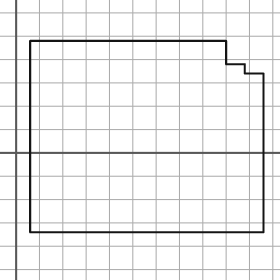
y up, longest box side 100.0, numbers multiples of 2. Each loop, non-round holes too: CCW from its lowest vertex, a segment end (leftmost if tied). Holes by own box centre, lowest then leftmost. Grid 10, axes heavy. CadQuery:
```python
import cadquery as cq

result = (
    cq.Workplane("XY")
    .moveTo(6.0, -34.0)
    .lineTo(106.0, -34.0)
    .lineTo(106.0, 34.0)
    .lineTo(98.0, 34.0)
    .lineTo(98.0, 38.0)
    .lineTo(90.0, 38.0)
    .lineTo(90.0, 48.0)
    .lineTo(6.0, 48.0)
    .close()
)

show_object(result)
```